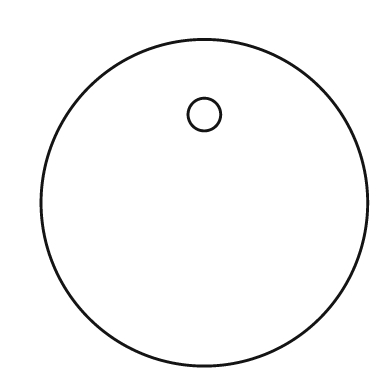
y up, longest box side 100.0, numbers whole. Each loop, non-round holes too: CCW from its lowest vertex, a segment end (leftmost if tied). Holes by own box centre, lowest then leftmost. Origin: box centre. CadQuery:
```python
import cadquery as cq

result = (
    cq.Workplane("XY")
    .moveTo(0.0, 0.0)
    .circle(50.0)
    .moveTo(0.0, 27.0)
    .circle(5.0)
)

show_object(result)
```